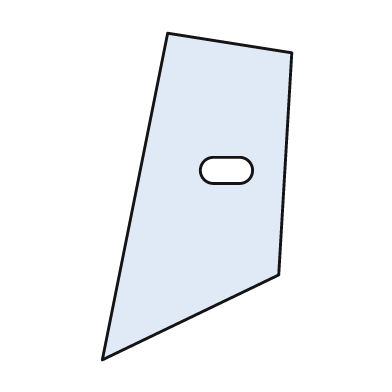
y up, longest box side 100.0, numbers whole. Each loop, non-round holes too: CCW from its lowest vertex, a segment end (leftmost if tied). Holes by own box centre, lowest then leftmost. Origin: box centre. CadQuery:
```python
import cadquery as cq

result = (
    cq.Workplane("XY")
    .moveTo(-29.0, -50.0)
    .lineTo(25.0, -24.0)
    .lineTo(29.0, 44.0)
    .lineTo(-9.0, 50.0)
    .close()
    .moveTo(5.0, 4.0)
    .lineTo(13.0, 4.0)
    .threePointArc((17.0, 8.0), (13.0, 12.0))
    .lineTo(5.0, 12.0)
    .threePointArc((1.0, 8.0), (5.0, 4.0))
    .close()
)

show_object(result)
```